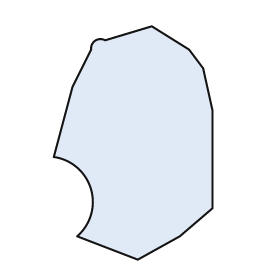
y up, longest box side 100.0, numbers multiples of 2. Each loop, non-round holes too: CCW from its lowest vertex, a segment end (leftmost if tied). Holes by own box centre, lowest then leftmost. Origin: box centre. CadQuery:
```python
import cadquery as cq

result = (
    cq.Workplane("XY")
    .moveTo(2.0, -50.0)
    .lineTo(20.0, -40.0)
    .lineTo(34.0, -28.0)
    .lineTo(34.0, 14.0)
    .lineTo(30.0, 32.0)
    .lineTo(24.0, 40.0)
    .lineTo(8.0, 50.0)
    .lineTo(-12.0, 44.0)
    .threePointArc((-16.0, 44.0), (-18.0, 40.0))
    .lineTo(-26.0, 24.0)
    .lineTo(-34.0, -6.0)
    .threePointArc((-18.0, -20.0), (-24.0, -40.0))
    .close()
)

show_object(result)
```